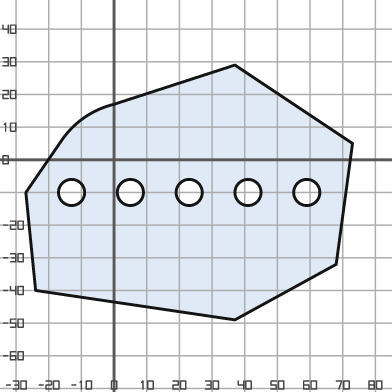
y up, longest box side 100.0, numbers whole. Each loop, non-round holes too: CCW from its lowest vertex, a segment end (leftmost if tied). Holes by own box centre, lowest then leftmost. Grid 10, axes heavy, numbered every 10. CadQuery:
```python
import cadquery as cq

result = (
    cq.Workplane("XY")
    .moveTo(37.0, -49.0)
    .lineTo(68.0, -32.0)
    .lineTo(73.0, 5.0)
    .lineTo(37.0, 29.0)
    .lineTo(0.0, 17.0)
    .threePointArc((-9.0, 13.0), (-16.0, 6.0))
    .lineTo(-27.0, -10.0)
    .lineTo(-24.0, -40.0)
    .close()
    .moveTo(-13.0, -10.0)
    .circle(4.0)
    .moveTo(5.0, -10.0)
    .circle(4.0)
    .moveTo(23.0, -10.0)
    .circle(4.0)
    .moveTo(41.0, -10.0)
    .circle(4.0)
    .moveTo(59.0, -10.0)
    .circle(4.0)
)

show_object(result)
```